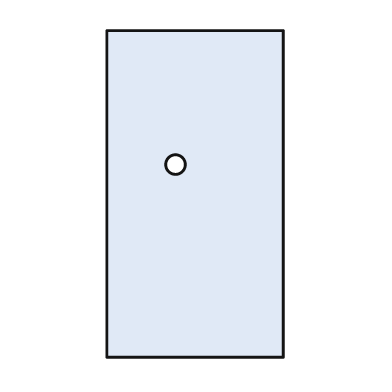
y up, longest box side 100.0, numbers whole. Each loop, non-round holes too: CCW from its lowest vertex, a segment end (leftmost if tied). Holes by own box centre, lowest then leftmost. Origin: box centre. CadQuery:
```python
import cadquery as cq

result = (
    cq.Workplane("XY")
    .moveTo(-27.0, -50.0)
    .lineTo(27.0, -50.0)
    .lineTo(27.0, 50.0)
    .lineTo(-27.0, 50.0)
    .close()
    .moveTo(-6.0, 9.0)
    .circle(3.0)
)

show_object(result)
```